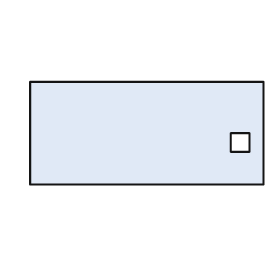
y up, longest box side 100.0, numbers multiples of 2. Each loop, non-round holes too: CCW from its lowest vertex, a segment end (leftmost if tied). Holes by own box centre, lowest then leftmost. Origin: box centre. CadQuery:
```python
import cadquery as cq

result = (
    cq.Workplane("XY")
    .moveTo(-50.0, -22.0)
    .lineTo(50.0, -22.0)
    .lineTo(50.0, 22.0)
    .lineTo(-50.0, 22.0)
    .close()
    .moveTo(36.0, -8.0)
    .lineTo(44.0, -8.0)
    .lineTo(44.0, 0.0)
    .lineTo(36.0, 0.0)
    .close()
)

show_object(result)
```